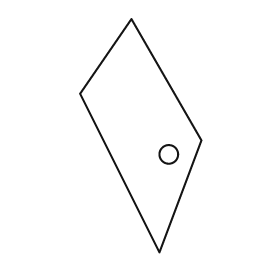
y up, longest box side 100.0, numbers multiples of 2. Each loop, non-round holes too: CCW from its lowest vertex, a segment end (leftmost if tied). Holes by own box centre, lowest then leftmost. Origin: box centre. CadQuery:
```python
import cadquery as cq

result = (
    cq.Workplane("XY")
    .moveTo(8.0, -50.0)
    .lineTo(26.0, -2.0)
    .lineTo(-4.0, 50.0)
    .lineTo(-26.0, 18.0)
    .close()
    .moveTo(12.0, -8.0)
    .circle(4.0)
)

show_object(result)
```